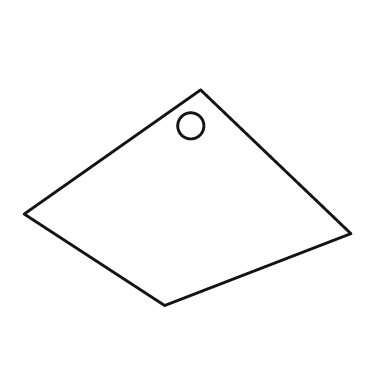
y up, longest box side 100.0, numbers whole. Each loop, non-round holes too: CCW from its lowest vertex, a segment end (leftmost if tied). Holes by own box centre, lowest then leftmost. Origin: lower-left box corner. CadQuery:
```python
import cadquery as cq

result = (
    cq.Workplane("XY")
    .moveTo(43.0, 0.0)
    .lineTo(100.0, 22.0)
    .lineTo(54.0, 66.0)
    .lineTo(0.0, 28.0)
    .close()
    .moveTo(51.0, 55.0)
    .circle(4.0)
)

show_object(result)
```